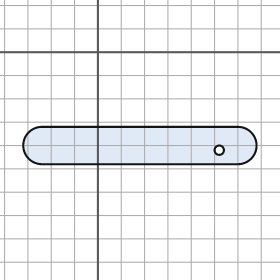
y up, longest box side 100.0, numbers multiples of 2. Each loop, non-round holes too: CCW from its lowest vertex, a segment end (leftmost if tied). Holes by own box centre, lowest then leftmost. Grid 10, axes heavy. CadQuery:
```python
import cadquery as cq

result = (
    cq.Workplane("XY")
    .moveTo(-24.0, -48.0)
    .lineTo(60.0, -48.0)
    .threePointArc((68.0, -40.0), (60.0, -32.0))
    .lineTo(-24.0, -32.0)
    .threePointArc((-32.0, -40.0), (-24.0, -48.0))
    .close()
    .moveTo(52.0, -42.0)
    .circle(2.0)
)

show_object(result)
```